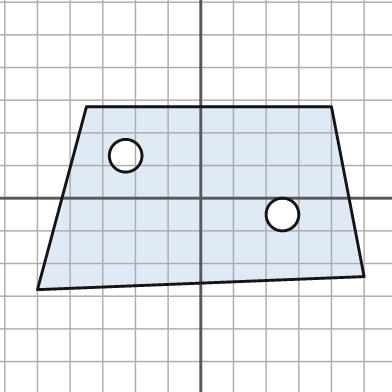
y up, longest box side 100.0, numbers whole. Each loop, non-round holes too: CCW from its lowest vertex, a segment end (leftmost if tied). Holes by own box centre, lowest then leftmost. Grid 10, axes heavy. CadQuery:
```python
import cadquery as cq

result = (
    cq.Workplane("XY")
    .moveTo(-50.0, -28.0)
    .lineTo(50.0, -24.0)
    .lineTo(40.0, 28.0)
    .lineTo(-35.0, 28.0)
    .close()
    .moveTo(25.0, -5.0)
    .circle(5.0)
    .moveTo(-23.0, 13.0)
    .circle(5.0)
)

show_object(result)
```